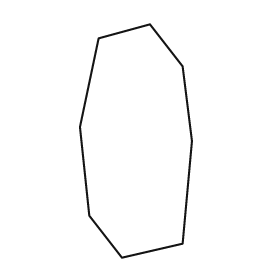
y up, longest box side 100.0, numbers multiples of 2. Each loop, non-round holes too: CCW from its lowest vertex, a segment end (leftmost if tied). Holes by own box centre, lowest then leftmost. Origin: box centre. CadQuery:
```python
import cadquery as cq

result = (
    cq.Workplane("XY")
    .moveTo(-6.0, -50.0)
    .lineTo(20.0, -44.0)
    .lineTo(24.0, 0.0)
    .lineTo(20.0, 32.0)
    .lineTo(6.0, 50.0)
    .lineTo(-16.0, 44.0)
    .lineTo(-24.0, 6.0)
    .lineTo(-20.0, -32.0)
    .close()
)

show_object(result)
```